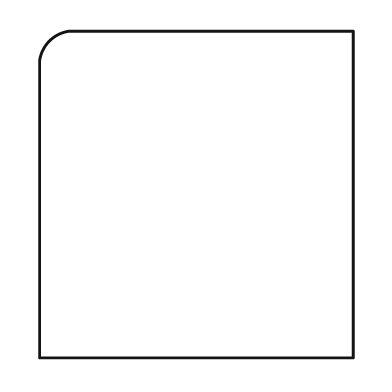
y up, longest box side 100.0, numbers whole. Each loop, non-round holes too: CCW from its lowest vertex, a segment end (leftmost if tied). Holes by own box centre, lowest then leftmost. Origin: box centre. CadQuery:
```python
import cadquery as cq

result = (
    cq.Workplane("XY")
    .moveTo(-48.0, -50.0)
    .lineTo(48.0, -50.0)
    .lineTo(48.0, 50.0)
    .lineTo(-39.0, 50.0)
    .threePointArc((-45.0, 47.0), (-48.0, 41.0))
    .close()
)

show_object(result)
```